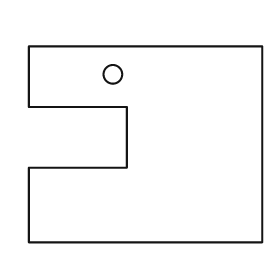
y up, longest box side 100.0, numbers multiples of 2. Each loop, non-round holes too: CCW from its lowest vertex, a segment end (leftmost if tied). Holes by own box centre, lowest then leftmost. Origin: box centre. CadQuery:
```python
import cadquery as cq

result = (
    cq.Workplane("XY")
    .moveTo(-50.0, -42.0)
    .lineTo(50.0, -42.0)
    .lineTo(50.0, 42.0)
    .lineTo(-50.0, 42.0)
    .lineTo(-50.0, 16.0)
    .lineTo(-8.0, 16.0)
    .lineTo(-8.0, -10.0)
    .lineTo(-50.0, -10.0)
    .close()
    .moveTo(-14.0, 30.0)
    .circle(4.0)
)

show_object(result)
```